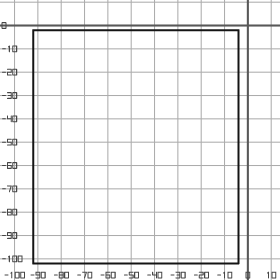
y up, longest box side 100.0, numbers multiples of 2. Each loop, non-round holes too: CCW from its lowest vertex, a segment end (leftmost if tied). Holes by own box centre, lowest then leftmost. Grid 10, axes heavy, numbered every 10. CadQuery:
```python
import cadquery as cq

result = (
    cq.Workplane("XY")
    .moveTo(-92.0, -102.0)
    .lineTo(-4.0, -102.0)
    .lineTo(-4.0, -2.0)
    .lineTo(-92.0, -2.0)
    .close()
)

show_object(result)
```